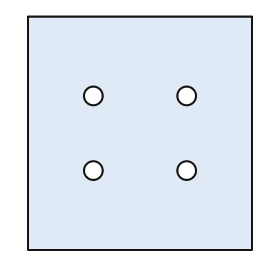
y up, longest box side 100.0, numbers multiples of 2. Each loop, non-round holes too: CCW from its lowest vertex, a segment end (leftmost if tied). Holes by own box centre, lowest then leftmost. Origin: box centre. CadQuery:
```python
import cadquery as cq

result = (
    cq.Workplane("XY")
    .moveTo(-48.0, -50.0)
    .lineTo(48.0, -50.0)
    .lineTo(48.0, 50.0)
    .lineTo(-48.0, 50.0)
    .close()
    .moveTo(-20.0, -16.0)
    .circle(4.0)
    .moveTo(20.0, -16.0)
    .circle(4.0)
    .moveTo(-20.0, 16.0)
    .circle(4.0)
    .moveTo(20.0, 16.0)
    .circle(4.0)
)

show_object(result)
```